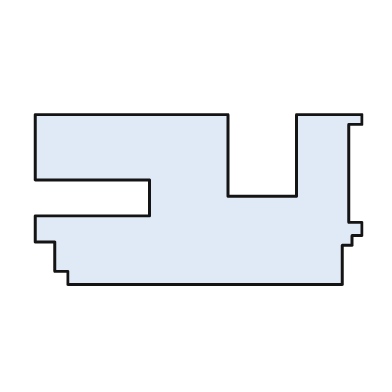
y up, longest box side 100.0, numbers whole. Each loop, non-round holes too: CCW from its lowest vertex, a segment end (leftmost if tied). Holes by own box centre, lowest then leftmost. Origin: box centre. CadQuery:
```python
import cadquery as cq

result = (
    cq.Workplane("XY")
    .moveTo(-40.0, -26.0)
    .lineTo(44.0, -26.0)
    .lineTo(44.0, -14.0)
    .lineTo(47.0, -14.0)
    .lineTo(47.0, -11.0)
    .lineTo(50.0, -11.0)
    .lineTo(50.0, -7.0)
    .lineTo(46.0, -7.0)
    .lineTo(46.0, 23.0)
    .lineTo(50.0, 23.0)
    .lineTo(50.0, 26.0)
    .lineTo(30.0, 26.0)
    .lineTo(30.0, 1.0)
    .lineTo(9.0, 1.0)
    .lineTo(9.0, 26.0)
    .lineTo(-50.0, 26.0)
    .lineTo(-50.0, 6.0)
    .lineTo(-15.0, 6.0)
    .lineTo(-15.0, -5.0)
    .lineTo(-50.0, -5.0)
    .lineTo(-50.0, -13.0)
    .lineTo(-44.0, -13.0)
    .lineTo(-44.0, -22.0)
    .lineTo(-40.0, -22.0)
    .close()
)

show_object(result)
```